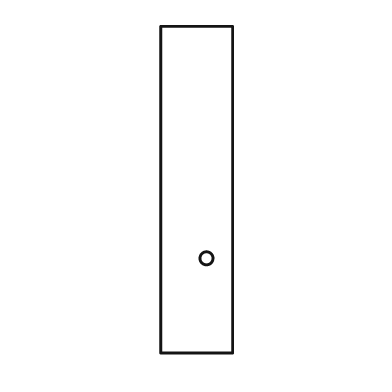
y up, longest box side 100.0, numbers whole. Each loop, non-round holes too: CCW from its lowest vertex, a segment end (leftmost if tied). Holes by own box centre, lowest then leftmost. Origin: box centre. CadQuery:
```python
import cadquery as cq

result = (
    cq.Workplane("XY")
    .moveTo(-11.0, -50.0)
    .lineTo(11.0, -50.0)
    .lineTo(11.0, 50.0)
    .lineTo(-11.0, 50.0)
    .close()
    .moveTo(3.0, -21.0)
    .circle(2.0)
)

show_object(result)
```